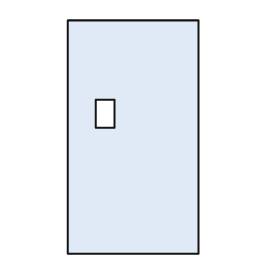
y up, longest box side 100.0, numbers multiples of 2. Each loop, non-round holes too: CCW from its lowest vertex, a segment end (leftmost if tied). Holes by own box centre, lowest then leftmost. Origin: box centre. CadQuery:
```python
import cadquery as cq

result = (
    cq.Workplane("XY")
    .moveTo(-28.0, -50.0)
    .lineTo(28.0, -50.0)
    .lineTo(28.0, 50.0)
    .lineTo(-28.0, 50.0)
    .close()
    .moveTo(-16.0, 4.0)
    .lineTo(-8.0, 4.0)
    .lineTo(-8.0, 16.0)
    .lineTo(-16.0, 16.0)
    .close()
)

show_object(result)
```